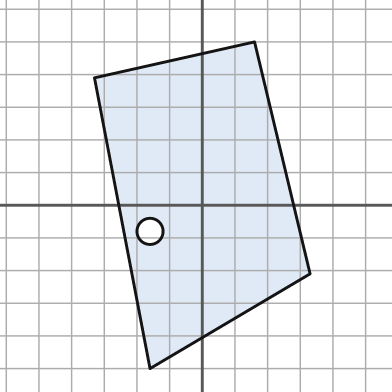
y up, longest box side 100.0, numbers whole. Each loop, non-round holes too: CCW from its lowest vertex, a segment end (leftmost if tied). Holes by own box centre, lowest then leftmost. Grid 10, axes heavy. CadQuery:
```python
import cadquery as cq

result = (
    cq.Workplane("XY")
    .moveTo(-16.0, -50.0)
    .lineTo(33.0, -21.0)
    .lineTo(16.0, 50.0)
    .lineTo(-33.0, 39.0)
    .close()
    .moveTo(-16.0, -8.0)
    .circle(4.0)
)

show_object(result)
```